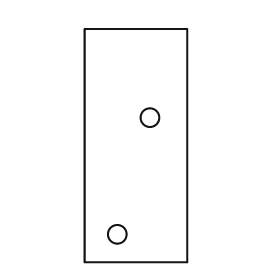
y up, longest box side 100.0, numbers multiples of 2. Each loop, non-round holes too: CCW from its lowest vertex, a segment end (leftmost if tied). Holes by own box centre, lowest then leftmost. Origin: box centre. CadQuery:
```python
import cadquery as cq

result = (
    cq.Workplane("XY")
    .moveTo(-22.0, -50.0)
    .lineTo(22.0, -50.0)
    .lineTo(22.0, 50.0)
    .lineTo(-22.0, 50.0)
    .close()
    .moveTo(-8.0, -38.0)
    .circle(4.0)
    .moveTo(6.0, 12.0)
    .circle(4.0)
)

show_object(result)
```